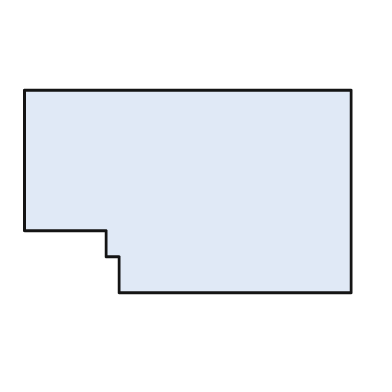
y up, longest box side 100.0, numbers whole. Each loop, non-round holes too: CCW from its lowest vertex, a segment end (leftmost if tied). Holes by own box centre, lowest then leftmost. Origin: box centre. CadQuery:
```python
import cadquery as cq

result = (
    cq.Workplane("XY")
    .moveTo(-21.0, -31.0)
    .lineTo(50.0, -31.0)
    .lineTo(50.0, 31.0)
    .lineTo(-50.0, 31.0)
    .lineTo(-50.0, -12.0)
    .lineTo(-25.0, -12.0)
    .lineTo(-25.0, -20.0)
    .lineTo(-21.0, -20.0)
    .close()
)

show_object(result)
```